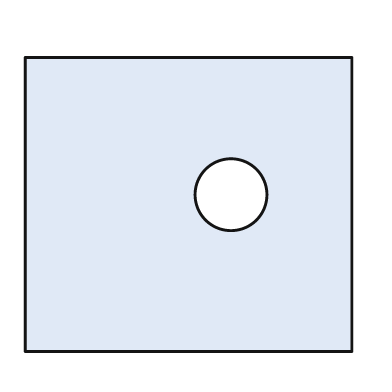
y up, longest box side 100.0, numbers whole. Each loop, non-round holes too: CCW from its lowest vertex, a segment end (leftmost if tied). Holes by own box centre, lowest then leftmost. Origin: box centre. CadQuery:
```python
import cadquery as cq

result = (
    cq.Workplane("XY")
    .moveTo(-50.0, -45.0)
    .lineTo(50.0, -45.0)
    .lineTo(50.0, 45.0)
    .lineTo(-50.0, 45.0)
    .close()
    .moveTo(13.0, 3.0)
    .circle(11.0)
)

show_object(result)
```